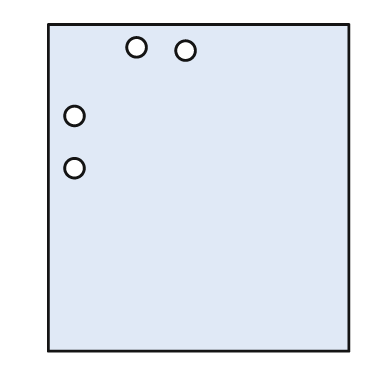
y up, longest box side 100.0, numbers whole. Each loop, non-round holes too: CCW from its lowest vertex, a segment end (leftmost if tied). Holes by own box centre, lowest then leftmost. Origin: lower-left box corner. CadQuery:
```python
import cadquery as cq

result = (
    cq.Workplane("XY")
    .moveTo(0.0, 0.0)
    .lineTo(92.0, 0.0)
    .lineTo(92.0, 100.0)
    .lineTo(0.0, 100.0)
    .close()
    .moveTo(8.0, 56.0)
    .circle(3.0)
    .moveTo(8.0, 72.0)
    .circle(3.0)
    .moveTo(42.0, 92.0)
    .circle(3.0)
    .moveTo(27.0, 93.0)
    .circle(3.0)
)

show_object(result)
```